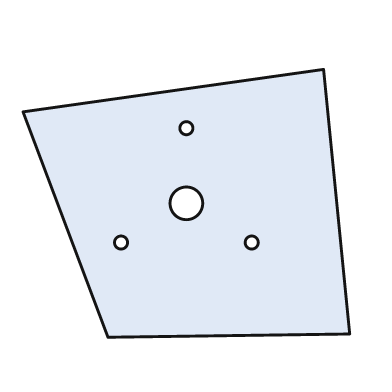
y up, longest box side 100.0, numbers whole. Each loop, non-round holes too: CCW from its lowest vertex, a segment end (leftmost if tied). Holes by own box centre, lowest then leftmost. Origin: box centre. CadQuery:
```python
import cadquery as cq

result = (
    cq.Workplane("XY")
    .moveTo(-24.0, -41.0)
    .lineTo(50.0, -40.0)
    .lineTo(42.0, 41.0)
    .lineTo(-50.0, 28.0)
    .close()
    .moveTo(-20.0, -12.0)
    .circle(2.0)
    .moveTo(20.0, -12.0)
    .circle(2.0)
    .moveTo(0.0, 0.0)
    .circle(5.0)
    .moveTo(0.0, 23.0)
    .circle(2.0)
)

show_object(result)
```